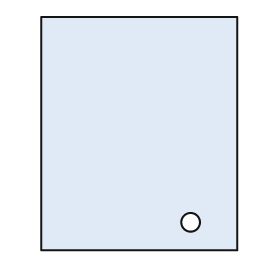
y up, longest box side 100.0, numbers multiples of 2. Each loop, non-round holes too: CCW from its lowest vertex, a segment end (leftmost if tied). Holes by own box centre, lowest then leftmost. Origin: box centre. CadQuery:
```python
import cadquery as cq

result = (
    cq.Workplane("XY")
    .moveTo(-42.0, -50.0)
    .lineTo(42.0, -50.0)
    .lineTo(42.0, 50.0)
    .lineTo(-42.0, 50.0)
    .close()
    .moveTo(22.0, -38.0)
    .circle(4.0)
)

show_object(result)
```